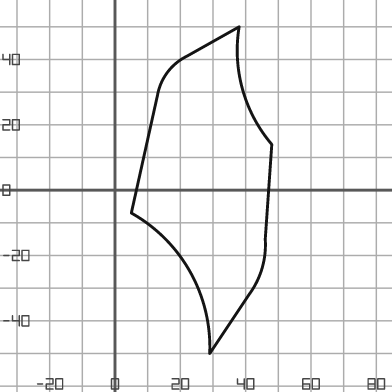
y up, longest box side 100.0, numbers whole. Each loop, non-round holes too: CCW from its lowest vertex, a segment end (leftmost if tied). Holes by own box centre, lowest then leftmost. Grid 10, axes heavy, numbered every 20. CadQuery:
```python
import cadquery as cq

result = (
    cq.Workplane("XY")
    .moveTo(29.0, -50.0)
    .lineTo(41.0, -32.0)
    .threePointArc((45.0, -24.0), (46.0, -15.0))
    .lineTo(48.0, 14.0)
    .threePointArc((39.0, 31.0), (38.0, 50.0))
    .lineTo(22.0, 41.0)
    .threePointArc((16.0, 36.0), (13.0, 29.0))
    .lineTo(5.0, -7.0)
    .threePointArc((23.0, -25.0), (29.0, -50.0))
    .close()
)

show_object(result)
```